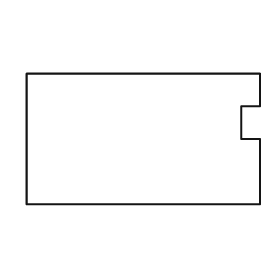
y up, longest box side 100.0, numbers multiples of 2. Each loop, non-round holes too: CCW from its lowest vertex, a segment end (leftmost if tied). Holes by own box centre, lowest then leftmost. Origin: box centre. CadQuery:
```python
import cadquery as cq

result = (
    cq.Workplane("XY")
    .moveTo(-50.0, -28.0)
    .lineTo(50.0, -28.0)
    .lineTo(50.0, 0.0)
    .lineTo(42.0, 0.0)
    .lineTo(42.0, 14.0)
    .lineTo(50.0, 14.0)
    .lineTo(50.0, 28.0)
    .lineTo(-50.0, 28.0)
    .close()
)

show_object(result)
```